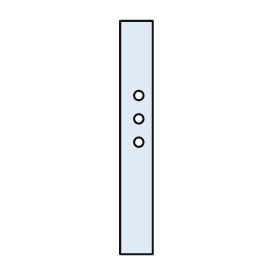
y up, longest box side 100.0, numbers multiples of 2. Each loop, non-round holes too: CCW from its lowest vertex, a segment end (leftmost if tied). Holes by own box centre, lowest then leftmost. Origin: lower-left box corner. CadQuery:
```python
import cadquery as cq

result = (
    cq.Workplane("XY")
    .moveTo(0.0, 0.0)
    .lineTo(14.0, 0.0)
    .lineTo(14.0, 100.0)
    .lineTo(0.0, 100.0)
    .close()
    .moveTo(8.0, 48.0)
    .circle(2.0)
    .moveTo(8.0, 58.0)
    .circle(2.0)
    .moveTo(8.0, 68.0)
    .circle(2.0)
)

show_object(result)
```